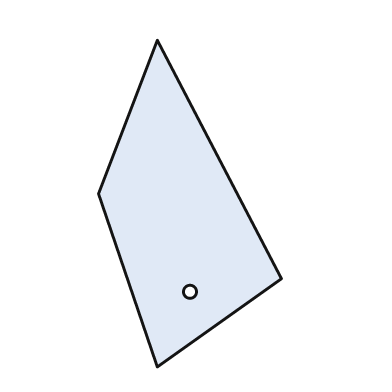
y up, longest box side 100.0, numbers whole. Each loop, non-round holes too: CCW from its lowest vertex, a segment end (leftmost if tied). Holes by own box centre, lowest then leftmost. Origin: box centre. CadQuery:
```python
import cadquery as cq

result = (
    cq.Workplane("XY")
    .moveTo(-10.0, -50.0)
    .lineTo(28.0, -23.0)
    .lineTo(-10.0, 50.0)
    .lineTo(-28.0, 3.0)
    .close()
    .moveTo(0.0, -27.0)
    .circle(2.0)
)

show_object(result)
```